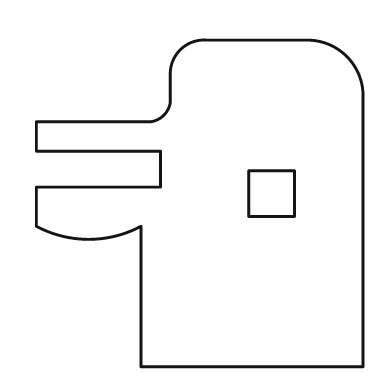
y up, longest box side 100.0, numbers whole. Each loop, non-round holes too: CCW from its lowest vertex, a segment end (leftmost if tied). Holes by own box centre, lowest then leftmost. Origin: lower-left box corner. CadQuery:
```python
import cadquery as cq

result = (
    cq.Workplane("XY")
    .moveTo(32.0, 0.0)
    .lineTo(100.0, 0.0)
    .lineTo(100.0, 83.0)
    .threePointArc((95.0, 95.0), (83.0, 100.0))
    .lineTo(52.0, 100.0)
    .threePointArc((44.0, 97.0), (41.0, 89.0))
    .lineTo(41.0, 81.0)
    .threePointArc((39.0, 77.0), (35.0, 75.0))
    .lineTo(0.0, 75.0)
    .lineTo(0.0, 66.0)
    .lineTo(38.0, 66.0)
    .lineTo(38.0, 55.0)
    .lineTo(0.0, 55.0)
    .lineTo(0.0, 43.0)
    .threePointArc((16.0, 39.0), (32.0, 43.0))
    .close()
    .moveTo(65.0, 46.0)
    .lineTo(79.0, 46.0)
    .lineTo(79.0, 60.0)
    .lineTo(65.0, 60.0)
    .close()
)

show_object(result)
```